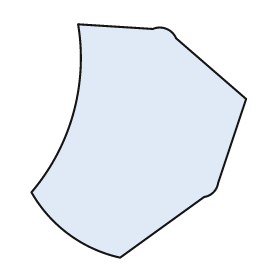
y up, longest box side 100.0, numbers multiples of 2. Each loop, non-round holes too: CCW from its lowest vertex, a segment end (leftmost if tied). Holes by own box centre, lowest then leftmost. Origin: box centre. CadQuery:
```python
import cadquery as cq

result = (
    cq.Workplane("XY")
    .moveTo(-8.0, -50.0)
    .lineTo(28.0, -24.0)
    .threePointArc((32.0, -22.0), (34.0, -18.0))
    .lineTo(46.0, 18.0)
    .lineTo(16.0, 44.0)
    .threePointArc((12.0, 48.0), (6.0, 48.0))
    .lineTo(-26.0, 50.0)
    .threePointArc((-28.0, 12.0), (-46.0, -22.0))
    .threePointArc((-30.0, -40.0), (-8.0, -50.0))
    .close()
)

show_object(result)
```